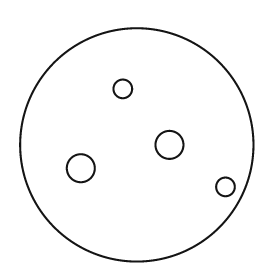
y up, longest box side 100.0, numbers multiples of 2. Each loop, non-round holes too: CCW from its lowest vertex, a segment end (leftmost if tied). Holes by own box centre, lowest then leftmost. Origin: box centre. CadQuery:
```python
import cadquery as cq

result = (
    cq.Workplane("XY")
    .moveTo(0.0, 0.0)
    .circle(50.0)
    .moveTo(38.0, -18.0)
    .circle(4.0)
    .moveTo(-24.0, -10.0)
    .circle(6.0)
    .moveTo(14.0, 0.0)
    .circle(6.0)
    .moveTo(-6.0, 24.0)
    .circle(4.0)
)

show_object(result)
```